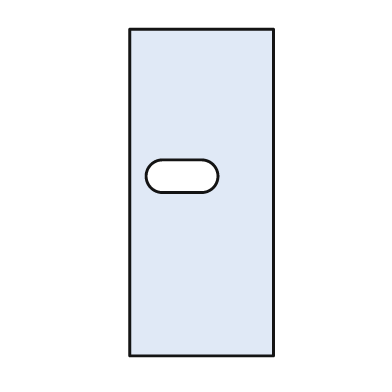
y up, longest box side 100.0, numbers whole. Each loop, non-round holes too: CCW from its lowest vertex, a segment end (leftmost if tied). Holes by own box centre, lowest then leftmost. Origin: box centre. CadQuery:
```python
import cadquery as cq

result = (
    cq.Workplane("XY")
    .moveTo(-22.0, -50.0)
    .lineTo(22.0, -50.0)
    .lineTo(22.0, 50.0)
    .lineTo(-22.0, 50.0)
    .close()
    .moveTo(-12.0, 0.0)
    .lineTo(0.0, 0.0)
    .threePointArc((5.0, 5.0), (0.0, 10.0))
    .lineTo(-12.0, 10.0)
    .threePointArc((-17.0, 5.0), (-12.0, 0.0))
    .close()
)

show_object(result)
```